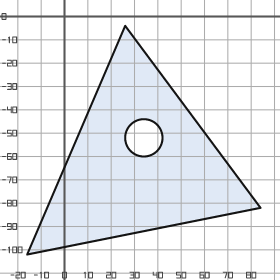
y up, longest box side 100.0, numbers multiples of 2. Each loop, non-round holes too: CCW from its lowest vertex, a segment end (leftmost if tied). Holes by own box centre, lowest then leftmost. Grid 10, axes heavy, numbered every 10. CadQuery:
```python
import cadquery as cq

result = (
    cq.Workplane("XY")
    .moveTo(-16.0, -102.0)
    .lineTo(84.0, -82.0)
    .lineTo(26.0, -4.0)
    .close()
    .moveTo(34.0, -52.0)
    .circle(8.0)
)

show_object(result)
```